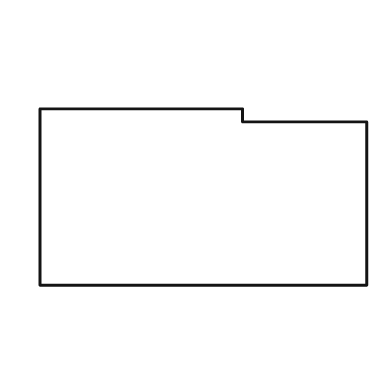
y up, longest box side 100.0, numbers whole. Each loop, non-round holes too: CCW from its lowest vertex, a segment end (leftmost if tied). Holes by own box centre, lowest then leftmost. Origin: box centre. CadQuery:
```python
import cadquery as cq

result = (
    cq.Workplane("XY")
    .moveTo(-50.0, -27.0)
    .lineTo(50.0, -27.0)
    .lineTo(50.0, 23.0)
    .lineTo(12.0, 23.0)
    .lineTo(12.0, 27.0)
    .lineTo(-50.0, 27.0)
    .close()
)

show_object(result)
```